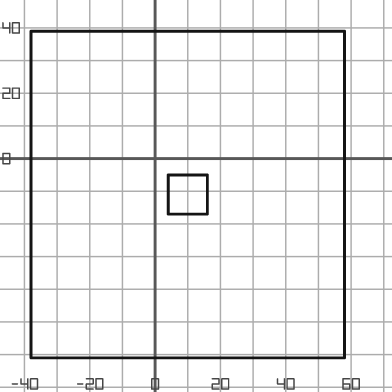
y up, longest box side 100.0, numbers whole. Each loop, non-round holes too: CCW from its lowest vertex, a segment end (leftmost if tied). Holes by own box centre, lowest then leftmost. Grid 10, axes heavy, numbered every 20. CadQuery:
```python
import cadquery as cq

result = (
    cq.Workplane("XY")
    .moveTo(-38.0, -61.0)
    .lineTo(58.0, -61.0)
    .lineTo(58.0, 39.0)
    .lineTo(-38.0, 39.0)
    .close()
    .moveTo(4.0, -17.0)
    .lineTo(16.0, -17.0)
    .lineTo(16.0, -5.0)
    .lineTo(4.0, -5.0)
    .close()
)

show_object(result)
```